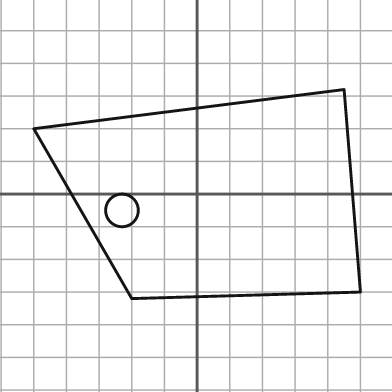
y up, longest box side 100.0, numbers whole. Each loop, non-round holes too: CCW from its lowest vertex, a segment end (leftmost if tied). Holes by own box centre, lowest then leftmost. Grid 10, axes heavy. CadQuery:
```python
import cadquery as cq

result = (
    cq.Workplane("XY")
    .moveTo(-20.0, -32.0)
    .lineTo(50.0, -30.0)
    .lineTo(45.0, 32.0)
    .lineTo(-50.0, 20.0)
    .close()
    .moveTo(-23.0, -5.0)
    .circle(5.0)
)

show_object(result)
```